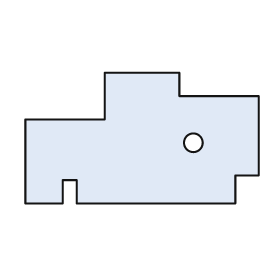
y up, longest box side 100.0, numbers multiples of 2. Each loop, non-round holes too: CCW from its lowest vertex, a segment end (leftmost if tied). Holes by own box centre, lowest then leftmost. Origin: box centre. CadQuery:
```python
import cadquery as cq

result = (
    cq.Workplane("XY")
    .moveTo(-50.0, -28.0)
    .lineTo(-34.0, -28.0)
    .lineTo(-34.0, -18.0)
    .lineTo(-28.0, -18.0)
    .lineTo(-28.0, -28.0)
    .lineTo(40.0, -28.0)
    .lineTo(40.0, -16.0)
    .lineTo(50.0, -16.0)
    .lineTo(50.0, 18.0)
    .lineTo(16.0, 18.0)
    .lineTo(16.0, 28.0)
    .lineTo(-16.0, 28.0)
    .lineTo(-16.0, 8.0)
    .lineTo(-50.0, 8.0)
    .close()
    .moveTo(22.0, -2.0)
    .circle(4.0)
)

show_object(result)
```